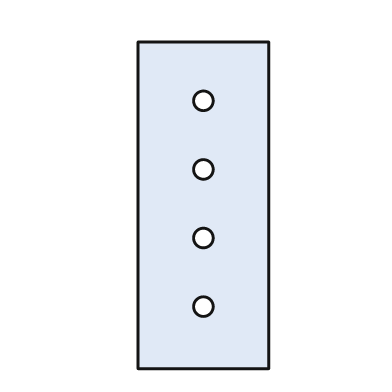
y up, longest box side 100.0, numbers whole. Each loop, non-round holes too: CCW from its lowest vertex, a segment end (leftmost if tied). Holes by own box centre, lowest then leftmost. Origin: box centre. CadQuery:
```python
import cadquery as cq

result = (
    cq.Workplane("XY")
    .moveTo(-20.0, -50.0)
    .lineTo(20.0, -50.0)
    .lineTo(20.0, 50.0)
    .lineTo(-20.0, 50.0)
    .close()
    .moveTo(0.0, -31.0)
    .circle(3.0)
    .moveTo(0.0, -10.0)
    .circle(3.0)
    .moveTo(0.0, 11.0)
    .circle(3.0)
    .moveTo(0.0, 32.0)
    .circle(3.0)
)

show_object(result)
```